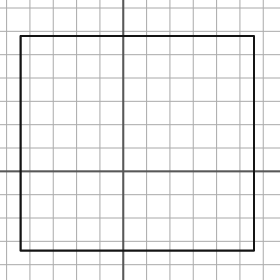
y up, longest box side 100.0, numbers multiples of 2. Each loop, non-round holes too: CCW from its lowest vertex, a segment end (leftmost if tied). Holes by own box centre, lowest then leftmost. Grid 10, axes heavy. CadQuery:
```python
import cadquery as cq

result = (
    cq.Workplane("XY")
    .moveTo(-44.0, -34.0)
    .lineTo(56.0, -34.0)
    .lineTo(56.0, 58.0)
    .lineTo(-44.0, 58.0)
    .close()
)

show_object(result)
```